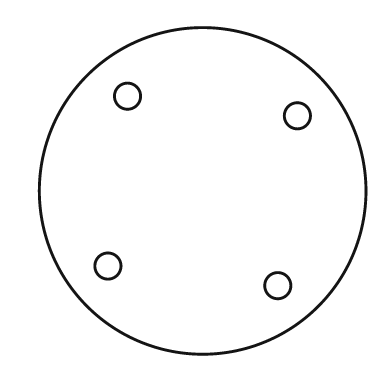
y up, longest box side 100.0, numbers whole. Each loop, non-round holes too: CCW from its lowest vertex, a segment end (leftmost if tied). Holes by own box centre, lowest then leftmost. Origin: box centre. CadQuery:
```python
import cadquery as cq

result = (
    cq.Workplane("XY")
    .moveTo(0.0, 0.0)
    .circle(50.0)
    .moveTo(23.0, -29.0)
    .circle(4.0)
    .moveTo(-29.0, -23.0)
    .circle(4.0)
    .moveTo(29.0, 23.0)
    .circle(4.0)
    .moveTo(-23.0, 29.0)
    .circle(4.0)
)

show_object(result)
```